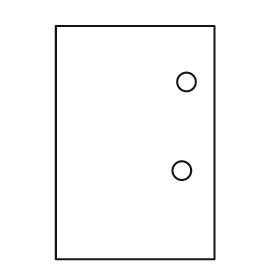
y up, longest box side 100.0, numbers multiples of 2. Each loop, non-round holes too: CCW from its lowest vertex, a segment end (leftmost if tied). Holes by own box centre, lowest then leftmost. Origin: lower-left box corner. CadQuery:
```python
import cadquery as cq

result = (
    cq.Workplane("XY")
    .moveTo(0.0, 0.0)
    .lineTo(68.0, 0.0)
    .lineTo(68.0, 100.0)
    .lineTo(0.0, 100.0)
    .close()
    .moveTo(54.0, 38.0)
    .circle(4.0)
    .moveTo(56.0, 76.0)
    .circle(4.0)
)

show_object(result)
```